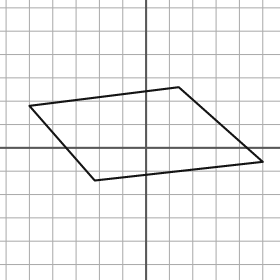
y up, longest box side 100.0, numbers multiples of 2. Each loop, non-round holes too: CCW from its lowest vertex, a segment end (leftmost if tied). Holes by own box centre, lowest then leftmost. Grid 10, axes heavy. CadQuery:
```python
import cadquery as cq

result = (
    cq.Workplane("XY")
    .moveTo(-22.0, -14.0)
    .lineTo(50.0, -6.0)
    .lineTo(14.0, 26.0)
    .lineTo(-50.0, 18.0)
    .close()
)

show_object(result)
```